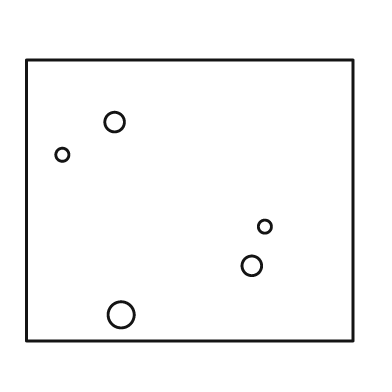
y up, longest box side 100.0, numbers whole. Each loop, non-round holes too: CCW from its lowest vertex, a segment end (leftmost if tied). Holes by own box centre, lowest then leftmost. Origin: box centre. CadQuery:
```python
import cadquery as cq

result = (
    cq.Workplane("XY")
    .moveTo(-50.0, -43.0)
    .lineTo(50.0, -43.0)
    .lineTo(50.0, 43.0)
    .lineTo(-50.0, 43.0)
    .close()
    .moveTo(-21.0, -35.0)
    .circle(4.0)
    .moveTo(19.0, -20.0)
    .circle(3.0)
    .moveTo(23.0, -8.0)
    .circle(2.0)
    .moveTo(-39.0, 14.0)
    .circle(2.0)
    .moveTo(-23.0, 24.0)
    .circle(3.0)
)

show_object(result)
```